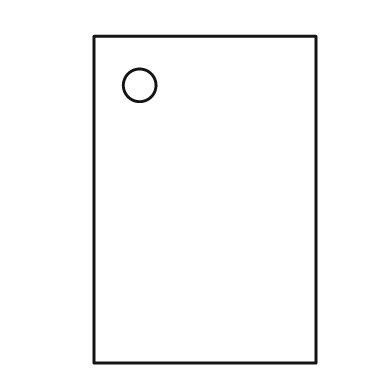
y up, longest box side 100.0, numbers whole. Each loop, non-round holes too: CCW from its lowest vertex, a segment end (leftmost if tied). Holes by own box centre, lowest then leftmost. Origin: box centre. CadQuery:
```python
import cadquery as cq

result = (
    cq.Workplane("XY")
    .moveTo(-34.0, -50.0)
    .lineTo(34.0, -50.0)
    .lineTo(34.0, 50.0)
    .lineTo(-34.0, 50.0)
    .close()
    .moveTo(-20.0, 35.0)
    .circle(5.0)
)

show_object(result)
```